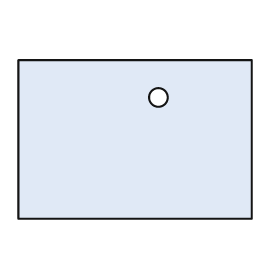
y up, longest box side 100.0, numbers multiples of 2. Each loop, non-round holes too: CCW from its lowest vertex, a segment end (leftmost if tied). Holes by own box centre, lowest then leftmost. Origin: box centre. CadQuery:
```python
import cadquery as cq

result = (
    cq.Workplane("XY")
    .moveTo(-50.0, -34.0)
    .lineTo(50.0, -34.0)
    .lineTo(50.0, 34.0)
    .lineTo(-50.0, 34.0)
    .close()
    .moveTo(10.0, 18.0)
    .circle(4.0)
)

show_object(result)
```